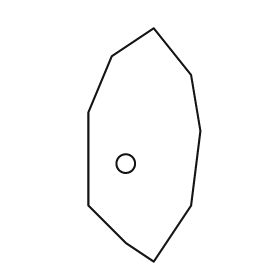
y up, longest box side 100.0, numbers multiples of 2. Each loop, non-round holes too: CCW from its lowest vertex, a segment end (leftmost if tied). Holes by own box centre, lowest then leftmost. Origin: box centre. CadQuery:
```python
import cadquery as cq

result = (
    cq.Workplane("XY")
    .moveTo(4.0, -50.0)
    .lineTo(20.0, -26.0)
    .lineTo(24.0, 6.0)
    .lineTo(20.0, 30.0)
    .lineTo(4.0, 50.0)
    .lineTo(-14.0, 38.0)
    .lineTo(-24.0, 14.0)
    .lineTo(-24.0, -26.0)
    .lineTo(-8.0, -42.0)
    .close()
    .moveTo(-8.0, -8.0)
    .circle(4.0)
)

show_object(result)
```